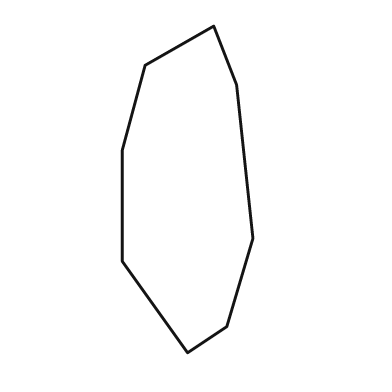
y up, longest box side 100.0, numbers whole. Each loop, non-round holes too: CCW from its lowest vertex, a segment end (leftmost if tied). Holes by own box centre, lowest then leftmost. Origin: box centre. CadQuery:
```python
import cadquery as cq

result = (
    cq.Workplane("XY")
    .moveTo(0.0, -50.0)
    .lineTo(12.0, -42.0)
    .lineTo(20.0, -15.0)
    .lineTo(15.0, 32.0)
    .lineTo(8.0, 50.0)
    .lineTo(-13.0, 38.0)
    .lineTo(-20.0, 12.0)
    .lineTo(-20.0, -22.0)
    .close()
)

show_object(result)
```